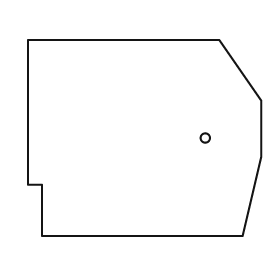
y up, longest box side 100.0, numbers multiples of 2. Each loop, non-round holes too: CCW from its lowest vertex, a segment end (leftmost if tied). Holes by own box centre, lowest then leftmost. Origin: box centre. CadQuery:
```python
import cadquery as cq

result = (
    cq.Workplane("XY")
    .moveTo(-44.0, -42.0)
    .lineTo(42.0, -42.0)
    .lineTo(50.0, -8.0)
    .lineTo(50.0, 16.0)
    .lineTo(32.0, 42.0)
    .lineTo(-50.0, 42.0)
    .lineTo(-50.0, -20.0)
    .lineTo(-44.0, -20.0)
    .close()
    .moveTo(26.0, 0.0)
    .circle(2.0)
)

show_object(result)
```